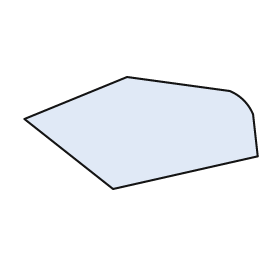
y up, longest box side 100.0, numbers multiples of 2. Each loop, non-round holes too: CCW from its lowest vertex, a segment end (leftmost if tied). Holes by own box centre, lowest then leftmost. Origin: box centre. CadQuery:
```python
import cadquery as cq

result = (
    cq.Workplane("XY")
    .moveTo(-12.0, -24.0)
    .lineTo(50.0, -10.0)
    .lineTo(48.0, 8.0)
    .threePointArc((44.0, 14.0), (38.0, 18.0))
    .lineTo(-6.0, 24.0)
    .lineTo(-50.0, 6.0)
    .close()
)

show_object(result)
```